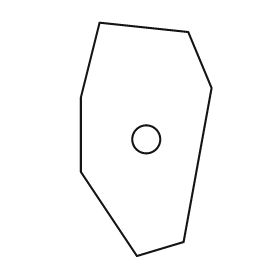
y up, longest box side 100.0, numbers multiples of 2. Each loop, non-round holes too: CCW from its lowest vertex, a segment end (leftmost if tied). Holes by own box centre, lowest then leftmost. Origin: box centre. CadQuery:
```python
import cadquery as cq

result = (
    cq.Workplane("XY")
    .moveTo(-4.0, -50.0)
    .lineTo(16.0, -44.0)
    .lineTo(28.0, 22.0)
    .lineTo(18.0, 46.0)
    .lineTo(-20.0, 50.0)
    .lineTo(-28.0, 18.0)
    .lineTo(-28.0, -14.0)
    .close()
    .moveTo(0.0, 0.0)
    .circle(6.0)
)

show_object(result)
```